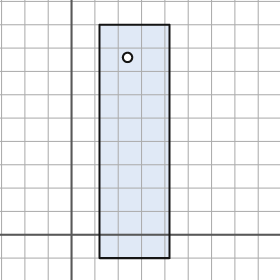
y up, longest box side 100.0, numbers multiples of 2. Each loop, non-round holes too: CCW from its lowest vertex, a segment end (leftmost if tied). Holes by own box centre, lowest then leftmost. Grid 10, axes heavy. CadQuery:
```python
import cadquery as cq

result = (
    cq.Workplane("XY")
    .moveTo(12.0, -10.0)
    .lineTo(42.0, -10.0)
    .lineTo(42.0, 90.0)
    .lineTo(12.0, 90.0)
    .close()
    .moveTo(24.0, 76.0)
    .circle(2.0)
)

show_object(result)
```